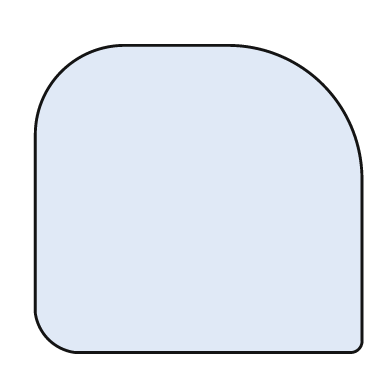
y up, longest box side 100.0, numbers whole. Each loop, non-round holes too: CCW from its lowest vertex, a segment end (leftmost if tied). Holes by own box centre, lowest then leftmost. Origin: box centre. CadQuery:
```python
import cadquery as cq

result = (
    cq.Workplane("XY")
    .moveTo(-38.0, -47.0)
    .lineTo(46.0, -47.0)
    .threePointArc((49.0, -46.0), (50.0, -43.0))
    .lineTo(50.0, 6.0)
    .threePointArc((38.0, 35.0), (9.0, 47.0))
    .lineTo(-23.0, 47.0)
    .threePointArc((-42.0, 39.0), (-50.0, 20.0))
    .lineTo(-50.0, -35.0)
    .threePointArc((-46.0, -43.0), (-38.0, -47.0))
    .close()
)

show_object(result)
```